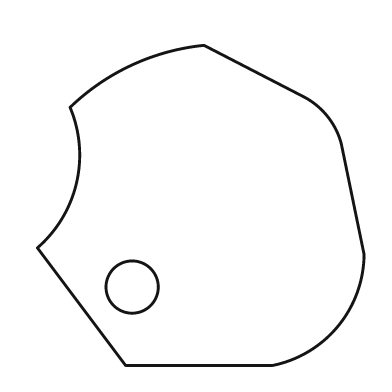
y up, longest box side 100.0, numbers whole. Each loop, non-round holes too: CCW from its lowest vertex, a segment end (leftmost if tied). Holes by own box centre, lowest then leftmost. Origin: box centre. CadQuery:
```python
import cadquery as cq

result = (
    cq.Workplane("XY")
    .moveTo(-23.0, -49.0)
    .lineTo(22.0, -49.0)
    .threePointArc((42.0, -37.0), (50.0, -15.0))
    .lineTo(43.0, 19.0)
    .threePointArc((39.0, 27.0), (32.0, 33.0))
    .lineTo(1.0, 49.0)
    .threePointArc((-21.0, 43.0), (-40.0, 30.0))
    .threePointArc((-38.0, 7.0), (-50.0, -13.0))
    .close()
    .moveTo(-21.0, -25.0)
    .circle(8.0)
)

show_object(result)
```